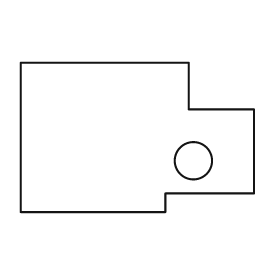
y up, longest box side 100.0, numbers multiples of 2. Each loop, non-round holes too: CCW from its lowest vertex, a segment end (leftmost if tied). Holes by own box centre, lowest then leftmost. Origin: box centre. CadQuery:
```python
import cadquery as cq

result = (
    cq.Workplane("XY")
    .moveTo(-50.0, -32.0)
    .lineTo(12.0, -32.0)
    .lineTo(12.0, -24.0)
    .lineTo(50.0, -24.0)
    .lineTo(50.0, 12.0)
    .lineTo(22.0, 12.0)
    .lineTo(22.0, 32.0)
    .lineTo(-50.0, 32.0)
    .close()
    .moveTo(24.0, -10.0)
    .circle(8.0)
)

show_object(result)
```